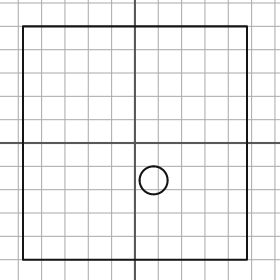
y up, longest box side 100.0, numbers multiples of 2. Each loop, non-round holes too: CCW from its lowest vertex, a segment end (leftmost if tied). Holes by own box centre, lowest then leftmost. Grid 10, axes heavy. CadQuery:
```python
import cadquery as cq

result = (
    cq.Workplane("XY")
    .moveTo(-48.0, -50.0)
    .lineTo(48.0, -50.0)
    .lineTo(48.0, 50.0)
    .lineTo(-48.0, 50.0)
    .close()
    .moveTo(8.0, -16.0)
    .circle(6.0)
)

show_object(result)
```